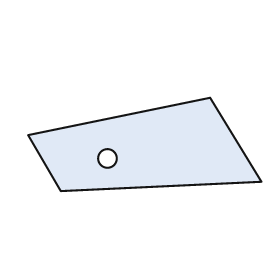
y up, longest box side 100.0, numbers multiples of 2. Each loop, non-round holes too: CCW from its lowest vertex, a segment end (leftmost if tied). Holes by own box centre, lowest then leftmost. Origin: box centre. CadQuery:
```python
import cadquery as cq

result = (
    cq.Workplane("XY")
    .moveTo(-36.0, -20.0)
    .lineTo(50.0, -16.0)
    .lineTo(28.0, 20.0)
    .lineTo(-50.0, 4.0)
    .close()
    .moveTo(-16.0, -6.0)
    .circle(4.0)
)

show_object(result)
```